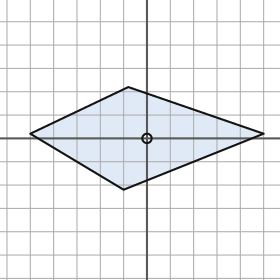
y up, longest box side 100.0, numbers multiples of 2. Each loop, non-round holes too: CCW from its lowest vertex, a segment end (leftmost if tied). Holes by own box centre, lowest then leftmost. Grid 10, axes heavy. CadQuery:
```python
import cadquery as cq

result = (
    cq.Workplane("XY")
    .moveTo(-10.0, -22.0)
    .lineTo(50.0, 2.0)
    .lineTo(-8.0, 22.0)
    .lineTo(-50.0, 2.0)
    .close()
    .moveTo(0.0, 0.0)
    .circle(2.0)
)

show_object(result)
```